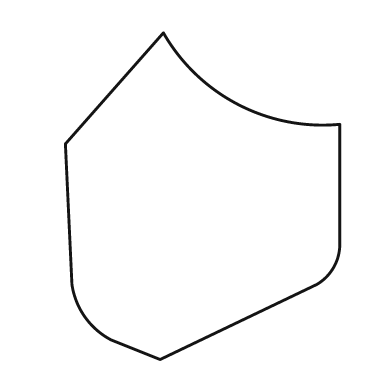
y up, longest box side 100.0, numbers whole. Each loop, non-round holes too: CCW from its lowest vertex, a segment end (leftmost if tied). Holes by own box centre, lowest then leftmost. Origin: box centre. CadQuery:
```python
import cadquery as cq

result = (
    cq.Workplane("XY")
    .moveTo(-13.0, -50.0)
    .lineTo(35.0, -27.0)
    .threePointArc((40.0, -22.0), (42.0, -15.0))
    .lineTo(42.0, 22.0)
    .threePointArc((11.0, 28.0), (-12.0, 50.0))
    .lineTo(-42.0, 16.0)
    .lineTo(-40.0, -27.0)
    .threePointArc((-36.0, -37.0), (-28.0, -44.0))
    .close()
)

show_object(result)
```